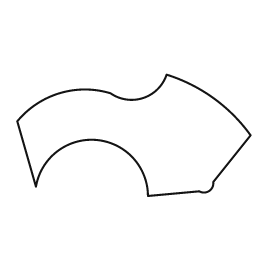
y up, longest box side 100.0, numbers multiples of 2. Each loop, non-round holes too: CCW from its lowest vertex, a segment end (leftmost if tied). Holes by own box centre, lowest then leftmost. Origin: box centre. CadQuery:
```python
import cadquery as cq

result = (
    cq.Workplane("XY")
    .moveTo(6.0, -26.0)
    .lineTo(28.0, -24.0)
    .threePointArc((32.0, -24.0), (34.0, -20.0))
    .lineTo(50.0, 0.0)
    .threePointArc((34.0, 16.0), (14.0, 26.0))
    .threePointArc((4.0, 16.0), (-10.0, 18.0))
    .threePointArc((-32.0, 18.0), (-50.0, 6.0))
    .lineTo(-42.0, -22.0)
    .threePointArc((-16.0, -2.0), (6.0, -26.0))
    .close()
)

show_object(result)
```